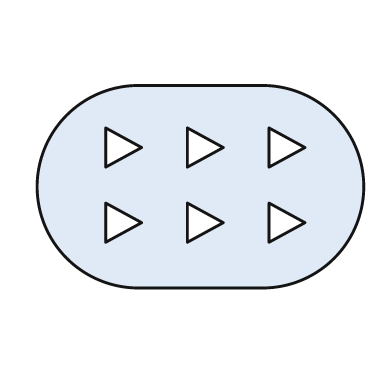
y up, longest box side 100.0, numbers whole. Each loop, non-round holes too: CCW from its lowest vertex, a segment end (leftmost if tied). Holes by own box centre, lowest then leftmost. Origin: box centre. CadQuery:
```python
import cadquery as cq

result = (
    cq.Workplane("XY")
    .moveTo(-19.0, -31.0)
    .lineTo(19.0, -31.0)
    .threePointArc((50.0, 0.0), (19.0, 31.0))
    .lineTo(-19.0, 31.0)
    .threePointArc((-50.0, 0.0), (-19.0, -31.0))
    .close()
    .moveTo(-29.0, -17.0)
    .lineTo(-18.0, -11.0)
    .lineTo(-29.0, -5.0)
    .close()
    .moveTo(-4.0, -17.0)
    .lineTo(7.0, -11.0)
    .lineTo(-4.0, -5.0)
    .close()
    .moveTo(21.0, -17.0)
    .lineTo(32.0, -11.0)
    .lineTo(21.0, -5.0)
    .close()
    .moveTo(-29.0, 6.0)
    .lineTo(-18.0, 12.0)
    .lineTo(-29.0, 18.0)
    .close()
    .moveTo(-4.0, 6.0)
    .lineTo(7.0, 12.0)
    .lineTo(-4.0, 18.0)
    .close()
    .moveTo(21.0, 6.0)
    .lineTo(32.0, 12.0)
    .lineTo(21.0, 18.0)
    .close()
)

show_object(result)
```